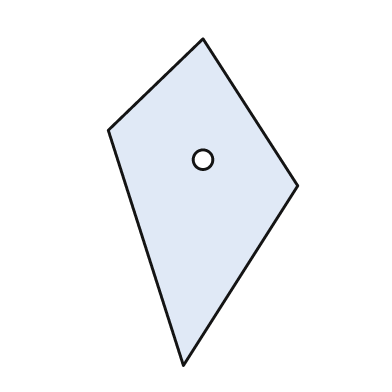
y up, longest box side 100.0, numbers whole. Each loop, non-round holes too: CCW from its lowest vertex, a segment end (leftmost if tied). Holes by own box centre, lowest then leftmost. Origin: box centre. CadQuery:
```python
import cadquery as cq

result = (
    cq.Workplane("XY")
    .moveTo(-6.0, -50.0)
    .lineTo(29.0, 5.0)
    .lineTo(0.0, 50.0)
    .lineTo(-29.0, 22.0)
    .close()
    .moveTo(0.0, 13.0)
    .circle(3.0)
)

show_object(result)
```